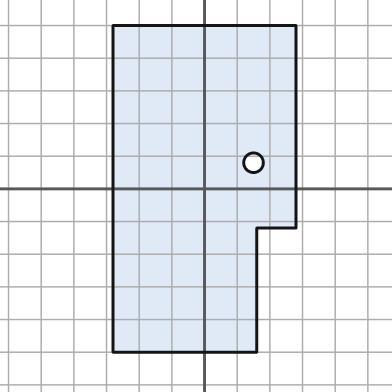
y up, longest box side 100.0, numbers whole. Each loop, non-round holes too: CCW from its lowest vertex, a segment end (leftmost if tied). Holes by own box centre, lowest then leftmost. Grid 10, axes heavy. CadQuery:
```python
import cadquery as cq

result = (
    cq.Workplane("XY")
    .moveTo(-28.0, -50.0)
    .lineTo(16.0, -50.0)
    .lineTo(16.0, -12.0)
    .lineTo(28.0, -12.0)
    .lineTo(28.0, 50.0)
    .lineTo(-28.0, 50.0)
    .close()
    .moveTo(15.0, 8.0)
    .circle(3.0)
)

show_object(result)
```